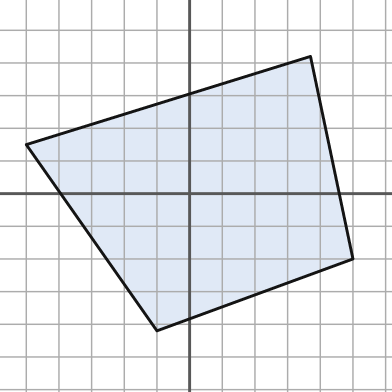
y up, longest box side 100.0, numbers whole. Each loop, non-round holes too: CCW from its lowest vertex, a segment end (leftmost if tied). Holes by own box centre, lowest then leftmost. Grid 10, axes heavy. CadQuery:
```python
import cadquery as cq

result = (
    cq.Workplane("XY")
    .moveTo(-10.0, -42.0)
    .lineTo(50.0, -20.0)
    .lineTo(37.0, 42.0)
    .lineTo(-50.0, 15.0)
    .close()
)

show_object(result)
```